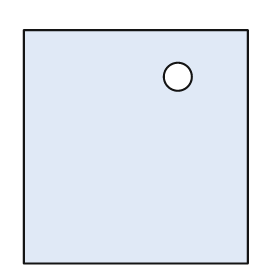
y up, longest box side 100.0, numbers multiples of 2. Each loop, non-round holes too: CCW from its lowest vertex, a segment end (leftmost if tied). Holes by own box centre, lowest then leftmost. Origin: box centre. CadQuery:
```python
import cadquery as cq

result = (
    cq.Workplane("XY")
    .moveTo(-48.0, -50.0)
    .lineTo(48.0, -50.0)
    .lineTo(48.0, 50.0)
    .lineTo(-48.0, 50.0)
    .close()
    .moveTo(18.0, 30.0)
    .circle(6.0)
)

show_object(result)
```